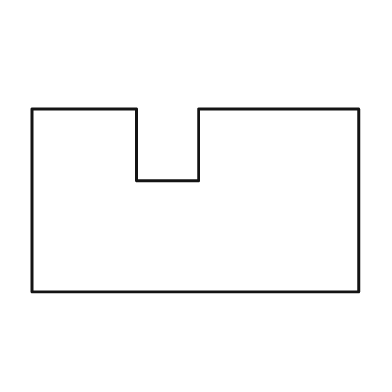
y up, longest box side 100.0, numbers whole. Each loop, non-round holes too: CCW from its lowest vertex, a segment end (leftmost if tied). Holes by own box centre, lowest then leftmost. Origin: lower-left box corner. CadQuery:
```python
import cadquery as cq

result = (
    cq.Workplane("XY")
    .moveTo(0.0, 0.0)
    .lineTo(100.0, 0.0)
    .lineTo(100.0, 56.0)
    .lineTo(51.0, 56.0)
    .lineTo(51.0, 34.0)
    .lineTo(32.0, 34.0)
    .lineTo(32.0, 56.0)
    .lineTo(0.0, 56.0)
    .close()
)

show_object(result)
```